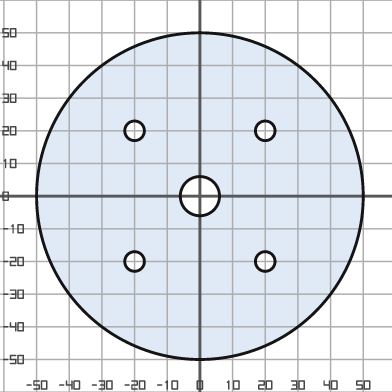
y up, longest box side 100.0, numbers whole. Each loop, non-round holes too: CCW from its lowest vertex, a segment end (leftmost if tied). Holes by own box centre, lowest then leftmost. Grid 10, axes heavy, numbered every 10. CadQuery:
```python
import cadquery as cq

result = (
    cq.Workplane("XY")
    .moveTo(0.0, 0.0)
    .circle(50.0)
    .moveTo(-20.0, -20.0)
    .circle(3.0)
    .moveTo(20.0, -20.0)
    .circle(3.0)
    .moveTo(0.0, 0.0)
    .circle(6.0)
    .moveTo(-20.0, 20.0)
    .circle(3.0)
    .moveTo(20.0, 20.0)
    .circle(3.0)
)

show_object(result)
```